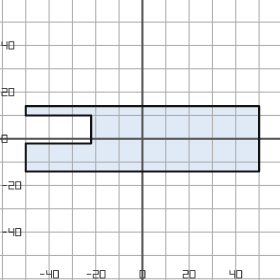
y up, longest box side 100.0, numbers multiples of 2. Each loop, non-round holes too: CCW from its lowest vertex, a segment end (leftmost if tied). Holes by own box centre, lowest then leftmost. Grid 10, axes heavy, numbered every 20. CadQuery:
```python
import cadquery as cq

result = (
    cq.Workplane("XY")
    .moveTo(-50.0, -14.0)
    .lineTo(50.0, -14.0)
    .lineTo(50.0, 14.0)
    .lineTo(-50.0, 14.0)
    .lineTo(-50.0, 10.0)
    .lineTo(-22.0, 10.0)
    .lineTo(-22.0, -2.0)
    .lineTo(-50.0, -2.0)
    .close()
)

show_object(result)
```